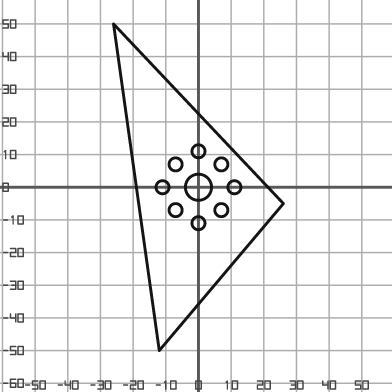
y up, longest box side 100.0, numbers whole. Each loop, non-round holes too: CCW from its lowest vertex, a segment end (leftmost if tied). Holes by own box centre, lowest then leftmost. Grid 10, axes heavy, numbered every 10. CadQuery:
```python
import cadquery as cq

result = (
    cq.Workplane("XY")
    .moveTo(-12.0, -50.0)
    .lineTo(26.0, -5.0)
    .lineTo(-26.0, 50.0)
    .close()
    .moveTo(0.0, -11.0)
    .circle(2.0)
    .moveTo(-7.0, -7.0)
    .circle(2.0)
    .moveTo(7.0, -7.0)
    .circle(2.0)
    .moveTo(-11.0, 0.0)
    .circle(2.0)
    .moveTo(0.0, 0.0)
    .circle(4.0)
    .moveTo(11.0, 0.0)
    .circle(2.0)
    .moveTo(-7.0, 7.0)
    .circle(2.0)
    .moveTo(7.0, 7.0)
    .circle(2.0)
    .moveTo(0.0, 11.0)
    .circle(2.0)
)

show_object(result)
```